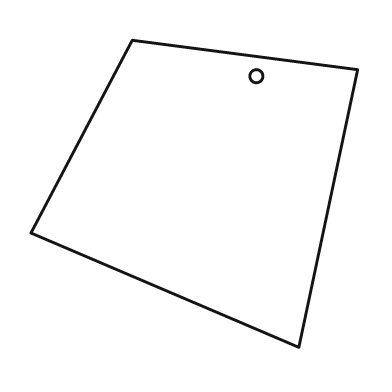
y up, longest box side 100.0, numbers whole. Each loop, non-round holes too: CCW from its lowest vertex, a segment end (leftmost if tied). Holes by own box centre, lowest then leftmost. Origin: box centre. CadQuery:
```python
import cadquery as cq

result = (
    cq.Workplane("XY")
    .moveTo(32.0, -47.0)
    .lineTo(50.0, 38.0)
    .lineTo(-19.0, 47.0)
    .lineTo(-50.0, -12.0)
    .close()
    .moveTo(19.0, 36.0)
    .circle(2.0)
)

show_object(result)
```